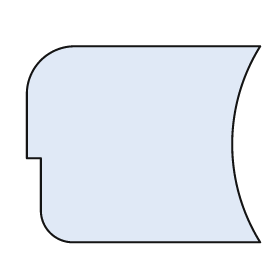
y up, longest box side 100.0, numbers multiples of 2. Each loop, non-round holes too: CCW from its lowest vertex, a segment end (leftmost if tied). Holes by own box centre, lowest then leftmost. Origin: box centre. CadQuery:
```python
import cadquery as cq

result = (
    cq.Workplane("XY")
    .moveTo(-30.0, -42.0)
    .lineTo(50.0, -42.0)
    .threePointArc((38.0, 0.0), (50.0, 42.0))
    .lineTo(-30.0, 42.0)
    .threePointArc((-44.0, 36.0), (-50.0, 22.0))
    .lineTo(-50.0, -6.0)
    .lineTo(-44.0, -6.0)
    .lineTo(-44.0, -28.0)
    .threePointArc((-40.0, -38.0), (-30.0, -42.0))
    .close()
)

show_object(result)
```